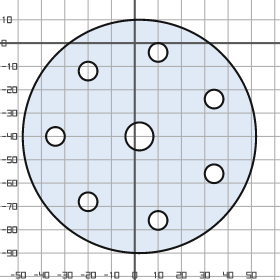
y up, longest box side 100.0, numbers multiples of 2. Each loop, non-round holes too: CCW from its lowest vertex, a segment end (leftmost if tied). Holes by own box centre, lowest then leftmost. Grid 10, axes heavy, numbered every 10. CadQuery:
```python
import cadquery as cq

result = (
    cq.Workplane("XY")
    .moveTo(2.0, -40.0)
    .circle(50.0)
    .moveTo(10.0, -76.0)
    .circle(4.0)
    .moveTo(-20.0, -68.0)
    .circle(4.0)
    .moveTo(34.0, -56.0)
    .circle(4.0)
    .moveTo(-34.0, -40.0)
    .circle(4.0)
    .moveTo(2.0, -40.0)
    .circle(6.0)
    .moveTo(34.0, -24.0)
    .circle(4.0)
    .moveTo(-20.0, -12.0)
    .circle(4.0)
    .moveTo(10.0, -4.0)
    .circle(4.0)
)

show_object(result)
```